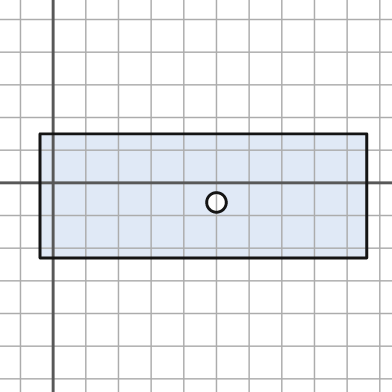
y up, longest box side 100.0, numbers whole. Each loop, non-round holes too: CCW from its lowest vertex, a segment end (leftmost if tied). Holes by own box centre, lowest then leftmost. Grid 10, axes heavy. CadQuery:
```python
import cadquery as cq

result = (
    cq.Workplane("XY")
    .moveTo(-4.0, -23.0)
    .lineTo(96.0, -23.0)
    .lineTo(96.0, 15.0)
    .lineTo(-4.0, 15.0)
    .close()
    .moveTo(50.0, -6.0)
    .circle(3.0)
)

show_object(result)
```